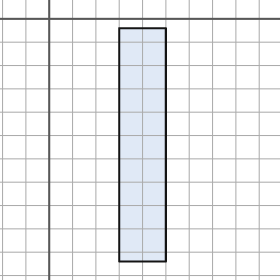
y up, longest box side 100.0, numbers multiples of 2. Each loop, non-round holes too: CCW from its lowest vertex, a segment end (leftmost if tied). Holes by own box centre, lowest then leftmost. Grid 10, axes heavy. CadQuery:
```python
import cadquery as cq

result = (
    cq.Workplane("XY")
    .moveTo(30.0, -104.0)
    .lineTo(50.0, -104.0)
    .lineTo(50.0, -4.0)
    .lineTo(30.0, -4.0)
    .close()
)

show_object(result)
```